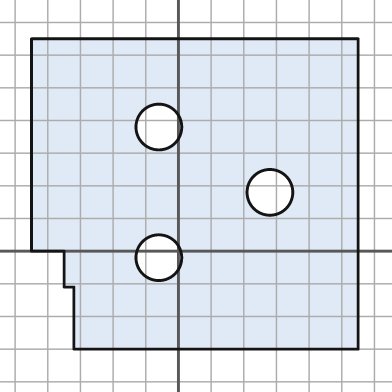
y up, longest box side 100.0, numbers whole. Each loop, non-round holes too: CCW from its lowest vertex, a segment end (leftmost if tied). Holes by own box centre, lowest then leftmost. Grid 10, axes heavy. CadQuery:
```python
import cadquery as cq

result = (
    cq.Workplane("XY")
    .moveTo(-32.0, -30.0)
    .lineTo(55.0, -30.0)
    .lineTo(55.0, 65.0)
    .lineTo(-45.0, 65.0)
    .lineTo(-45.0, 0.0)
    .lineTo(-35.0, 0.0)
    .lineTo(-35.0, -11.0)
    .lineTo(-32.0, -11.0)
    .close()
    .moveTo(-6.0, -2.0)
    .circle(7.0)
    .moveTo(28.0, 18.0)
    .circle(7.0)
    .moveTo(-6.0, 38.0)
    .circle(7.0)
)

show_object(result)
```